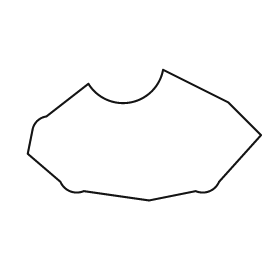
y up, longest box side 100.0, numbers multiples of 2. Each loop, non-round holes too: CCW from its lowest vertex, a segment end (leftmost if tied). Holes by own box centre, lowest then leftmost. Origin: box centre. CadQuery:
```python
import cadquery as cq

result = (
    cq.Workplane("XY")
    .moveTo(2.0, -28.0)
    .lineTo(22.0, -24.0)
    .threePointArc((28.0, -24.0), (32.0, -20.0))
    .lineTo(50.0, 0.0)
    .lineTo(36.0, 14.0)
    .lineTo(8.0, 28.0)
    .threePointArc((-6.0, 14.0), (-24.0, 22.0))
    .lineTo(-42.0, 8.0)
    .threePointArc((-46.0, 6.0), (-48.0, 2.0))
    .lineTo(-50.0, -8.0)
    .lineTo(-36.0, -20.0)
    .threePointArc((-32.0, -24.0), (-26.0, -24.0))
    .close()
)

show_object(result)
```